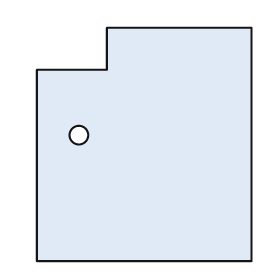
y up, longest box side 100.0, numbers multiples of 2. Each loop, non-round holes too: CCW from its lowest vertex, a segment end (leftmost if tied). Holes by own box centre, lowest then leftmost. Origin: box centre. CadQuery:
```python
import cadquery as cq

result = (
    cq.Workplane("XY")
    .moveTo(-46.0, -50.0)
    .lineTo(46.0, -50.0)
    .lineTo(46.0, 50.0)
    .lineTo(-16.0, 50.0)
    .lineTo(-16.0, 32.0)
    .lineTo(-46.0, 32.0)
    .close()
    .moveTo(-28.0, 4.0)
    .circle(4.0)
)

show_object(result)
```